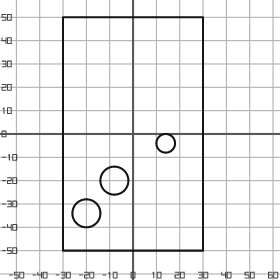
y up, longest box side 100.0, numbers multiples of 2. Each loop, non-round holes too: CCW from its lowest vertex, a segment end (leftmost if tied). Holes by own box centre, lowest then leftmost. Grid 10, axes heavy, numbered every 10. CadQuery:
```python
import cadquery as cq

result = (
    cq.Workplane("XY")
    .moveTo(-30.0, -50.0)
    .lineTo(30.0, -50.0)
    .lineTo(30.0, 50.0)
    .lineTo(-30.0, 50.0)
    .close()
    .moveTo(-20.0, -34.0)
    .circle(6.0)
    .moveTo(-8.0, -20.0)
    .circle(6.0)
    .moveTo(14.0, -4.0)
    .circle(4.0)
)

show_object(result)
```